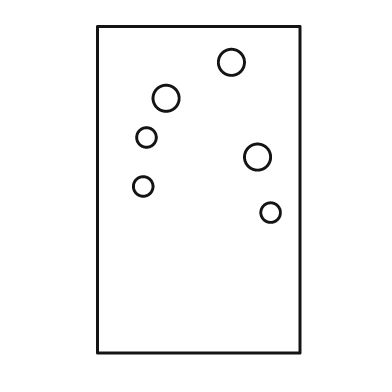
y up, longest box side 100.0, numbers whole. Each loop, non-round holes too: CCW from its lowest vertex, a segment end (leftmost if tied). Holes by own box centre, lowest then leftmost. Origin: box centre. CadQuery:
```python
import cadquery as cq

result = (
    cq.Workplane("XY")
    .moveTo(-31.0, -50.0)
    .lineTo(31.0, -50.0)
    .lineTo(31.0, 50.0)
    .lineTo(-31.0, 50.0)
    .close()
    .moveTo(22.0, -7.0)
    .circle(3.0)
    .moveTo(-17.0, 1.0)
    .circle(3.0)
    .moveTo(18.0, 10.0)
    .circle(4.0)
    .moveTo(-16.0, 16.0)
    .circle(3.0)
    .moveTo(-10.0, 28.0)
    .circle(4.0)
    .moveTo(10.0, 39.0)
    .circle(4.0)
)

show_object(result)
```